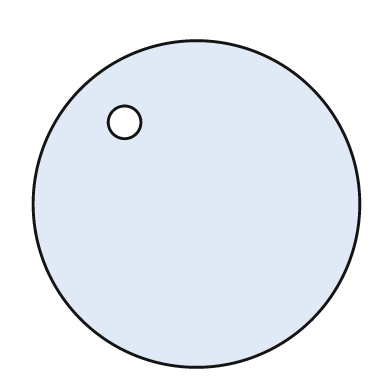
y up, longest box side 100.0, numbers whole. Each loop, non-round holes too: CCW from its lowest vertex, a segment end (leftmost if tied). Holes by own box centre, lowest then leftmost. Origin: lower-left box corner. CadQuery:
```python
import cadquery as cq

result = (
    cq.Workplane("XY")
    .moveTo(50.0, 50.0)
    .circle(50.0)
    .moveTo(28.0, 75.0)
    .circle(5.0)
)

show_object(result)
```